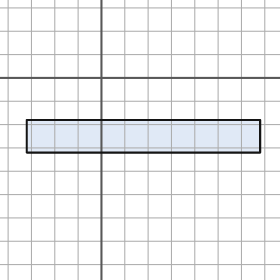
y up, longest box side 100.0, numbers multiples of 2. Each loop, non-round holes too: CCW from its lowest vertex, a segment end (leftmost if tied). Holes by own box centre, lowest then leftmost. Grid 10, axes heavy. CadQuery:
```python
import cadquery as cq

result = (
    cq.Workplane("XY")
    .moveTo(-32.0, -32.0)
    .lineTo(68.0, -32.0)
    .lineTo(68.0, -18.0)
    .lineTo(-32.0, -18.0)
    .close()
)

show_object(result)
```